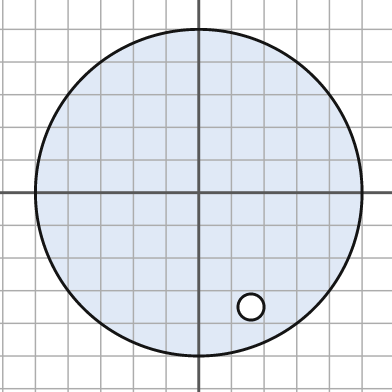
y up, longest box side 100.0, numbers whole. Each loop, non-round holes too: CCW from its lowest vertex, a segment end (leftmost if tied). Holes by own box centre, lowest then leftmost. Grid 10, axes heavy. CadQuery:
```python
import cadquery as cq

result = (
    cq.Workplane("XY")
    .moveTo(0.0, 0.0)
    .circle(50.0)
    .moveTo(16.0, -35.0)
    .circle(4.0)
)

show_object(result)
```